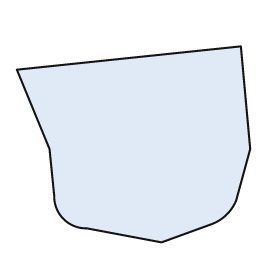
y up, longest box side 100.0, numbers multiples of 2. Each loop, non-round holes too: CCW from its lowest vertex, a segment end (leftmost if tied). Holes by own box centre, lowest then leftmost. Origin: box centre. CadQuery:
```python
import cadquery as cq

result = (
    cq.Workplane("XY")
    .moveTo(12.0, -42.0)
    .lineTo(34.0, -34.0)
    .threePointArc((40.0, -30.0), (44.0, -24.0))
    .lineTo(50.0, -2.0)
    .lineTo(46.0, 42.0)
    .lineTo(-50.0, 32.0)
    .lineTo(-36.0, -2.0)
    .lineTo(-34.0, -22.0)
    .threePointArc((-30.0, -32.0), (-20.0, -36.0))
    .close()
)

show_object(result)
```